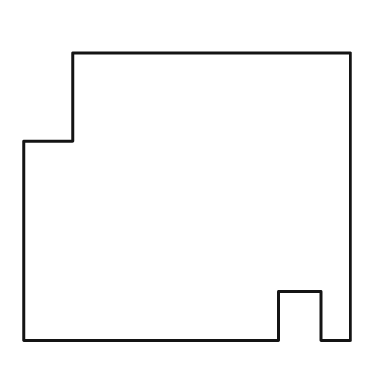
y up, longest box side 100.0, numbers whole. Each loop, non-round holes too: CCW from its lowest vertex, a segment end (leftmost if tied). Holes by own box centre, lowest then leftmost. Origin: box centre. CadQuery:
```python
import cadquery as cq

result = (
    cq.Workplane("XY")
    .moveTo(-50.0, -44.0)
    .lineTo(28.0, -44.0)
    .lineTo(28.0, -29.0)
    .lineTo(41.0, -29.0)
    .lineTo(41.0, -44.0)
    .lineTo(50.0, -44.0)
    .lineTo(50.0, 44.0)
    .lineTo(-35.0, 44.0)
    .lineTo(-35.0, 17.0)
    .lineTo(-50.0, 17.0)
    .close()
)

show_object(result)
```